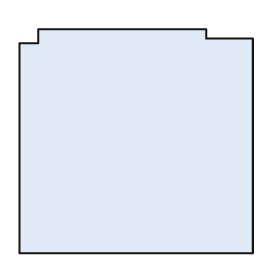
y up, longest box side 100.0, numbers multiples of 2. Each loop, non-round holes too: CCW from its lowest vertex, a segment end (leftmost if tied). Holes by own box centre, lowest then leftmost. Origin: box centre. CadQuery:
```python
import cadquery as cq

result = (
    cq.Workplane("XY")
    .moveTo(-50.0, -48.0)
    .lineTo(50.0, -48.0)
    .lineTo(50.0, 44.0)
    .lineTo(30.0, 44.0)
    .lineTo(30.0, 48.0)
    .lineTo(-42.0, 48.0)
    .lineTo(-42.0, 42.0)
    .lineTo(-50.0, 42.0)
    .close()
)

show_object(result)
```